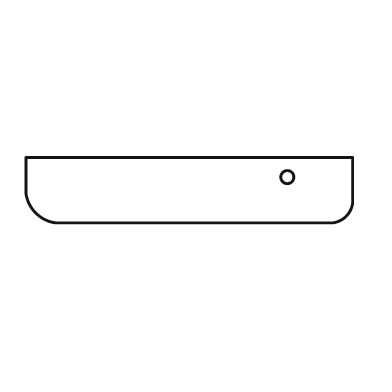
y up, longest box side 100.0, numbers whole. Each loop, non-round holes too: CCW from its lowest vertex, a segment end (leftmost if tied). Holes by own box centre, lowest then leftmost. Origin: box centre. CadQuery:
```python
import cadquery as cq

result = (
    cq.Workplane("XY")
    .moveTo(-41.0, -10.0)
    .lineTo(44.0, -10.0)
    .threePointArc((48.0, -8.0), (50.0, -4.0))
    .lineTo(50.0, 10.0)
    .lineTo(-50.0, 10.0)
    .lineTo(-50.0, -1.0)
    .threePointArc((-47.0, -7.0), (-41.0, -10.0))
    .close()
    .moveTo(30.0, 4.0)
    .circle(2.0)
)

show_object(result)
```